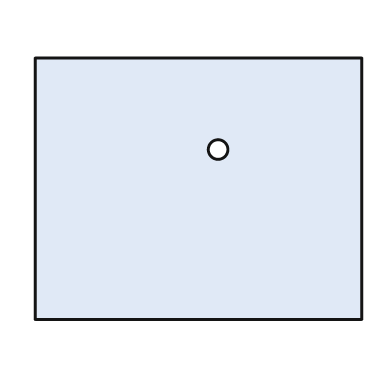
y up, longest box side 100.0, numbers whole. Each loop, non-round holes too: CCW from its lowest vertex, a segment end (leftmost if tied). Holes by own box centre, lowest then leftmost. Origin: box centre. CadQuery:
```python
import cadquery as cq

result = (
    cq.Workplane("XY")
    .moveTo(-50.0, -40.0)
    .lineTo(50.0, -40.0)
    .lineTo(50.0, 40.0)
    .lineTo(-50.0, 40.0)
    .close()
    .moveTo(6.0, 12.0)
    .circle(3.0)
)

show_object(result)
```